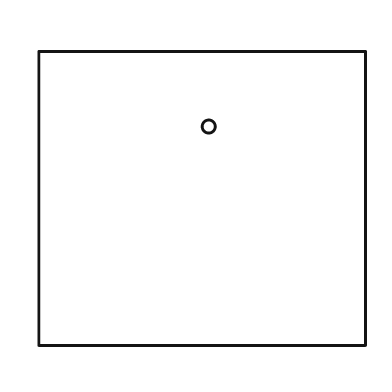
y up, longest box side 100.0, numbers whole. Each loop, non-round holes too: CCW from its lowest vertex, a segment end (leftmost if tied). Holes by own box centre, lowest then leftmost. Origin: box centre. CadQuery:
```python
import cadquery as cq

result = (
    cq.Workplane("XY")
    .moveTo(-50.0, -45.0)
    .lineTo(50.0, -45.0)
    .lineTo(50.0, 45.0)
    .lineTo(-50.0, 45.0)
    .close()
    .moveTo(2.0, 22.0)
    .circle(2.0)
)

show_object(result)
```